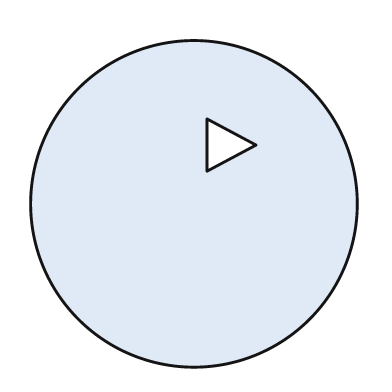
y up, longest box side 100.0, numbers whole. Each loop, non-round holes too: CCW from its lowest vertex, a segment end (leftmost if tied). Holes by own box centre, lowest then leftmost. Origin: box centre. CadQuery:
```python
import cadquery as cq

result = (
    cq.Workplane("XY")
    .moveTo(0.0, 0.0)
    .circle(50.0)
    .moveTo(4.0, 10.0)
    .lineTo(19.0, 18.0)
    .lineTo(4.0, 26.0)
    .close()
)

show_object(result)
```